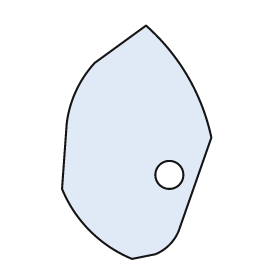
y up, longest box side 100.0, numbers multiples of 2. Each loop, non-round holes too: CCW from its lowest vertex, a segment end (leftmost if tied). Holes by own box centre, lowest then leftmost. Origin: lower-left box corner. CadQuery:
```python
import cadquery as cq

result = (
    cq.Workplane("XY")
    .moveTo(30.0, 0.0)
    .lineTo(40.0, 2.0)
    .threePointArc((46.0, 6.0), (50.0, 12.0))
    .lineTo(64.0, 52.0)
    .threePointArc((54.0, 78.0), (36.0, 100.0))
    .lineTo(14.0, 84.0)
    .threePointArc((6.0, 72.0), (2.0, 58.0))
    .lineTo(0.0, 30.0)
    .threePointArc((12.0, 12.0), (30.0, 0.0))
    .close()
    .moveTo(46.0, 36.0)
    .circle(6.0)
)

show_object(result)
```